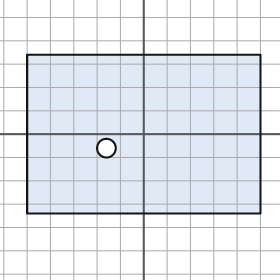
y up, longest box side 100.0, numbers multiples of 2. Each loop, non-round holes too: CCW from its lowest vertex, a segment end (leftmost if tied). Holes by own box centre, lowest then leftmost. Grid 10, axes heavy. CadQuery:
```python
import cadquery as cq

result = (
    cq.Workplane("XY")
    .moveTo(-50.0, -34.0)
    .lineTo(50.0, -34.0)
    .lineTo(50.0, 34.0)
    .lineTo(-50.0, 34.0)
    .close()
    .moveTo(-16.0, -6.0)
    .circle(4.0)
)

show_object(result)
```